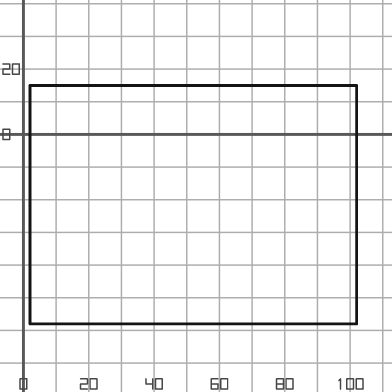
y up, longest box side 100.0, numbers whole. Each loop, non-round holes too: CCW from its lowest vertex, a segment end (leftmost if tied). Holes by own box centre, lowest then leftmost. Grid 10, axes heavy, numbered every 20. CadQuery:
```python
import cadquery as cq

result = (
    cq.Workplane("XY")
    .moveTo(2.0, -58.0)
    .lineTo(102.0, -58.0)
    .lineTo(102.0, 15.0)
    .lineTo(2.0, 15.0)
    .close()
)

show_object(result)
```